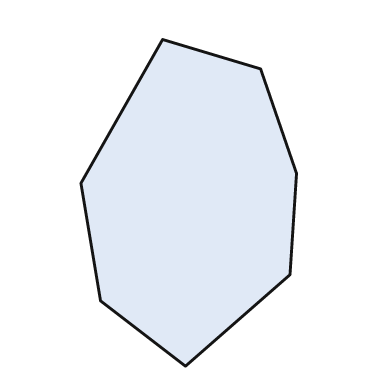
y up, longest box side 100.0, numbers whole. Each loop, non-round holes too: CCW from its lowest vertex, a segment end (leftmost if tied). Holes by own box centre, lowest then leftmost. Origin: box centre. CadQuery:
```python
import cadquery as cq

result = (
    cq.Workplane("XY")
    .moveTo(-1.0, -50.0)
    .lineTo(31.0, -22.0)
    .lineTo(33.0, 9.0)
    .lineTo(22.0, 41.0)
    .lineTo(-8.0, 50.0)
    .lineTo(-33.0, 6.0)
    .lineTo(-27.0, -30.0)
    .close()
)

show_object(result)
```